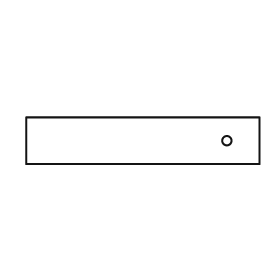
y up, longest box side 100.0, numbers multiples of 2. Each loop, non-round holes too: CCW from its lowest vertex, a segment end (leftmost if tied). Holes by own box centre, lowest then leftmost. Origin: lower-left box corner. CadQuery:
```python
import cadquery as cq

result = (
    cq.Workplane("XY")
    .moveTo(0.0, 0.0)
    .lineTo(100.0, 0.0)
    .lineTo(100.0, 20.0)
    .lineTo(0.0, 20.0)
    .close()
    .moveTo(86.0, 10.0)
    .circle(2.0)
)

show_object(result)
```